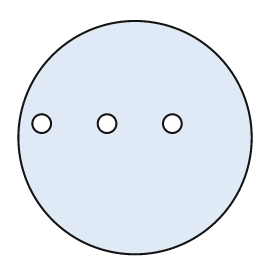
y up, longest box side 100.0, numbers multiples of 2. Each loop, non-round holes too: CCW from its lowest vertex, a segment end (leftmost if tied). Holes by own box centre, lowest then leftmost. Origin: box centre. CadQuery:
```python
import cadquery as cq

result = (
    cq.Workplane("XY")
    .moveTo(0.0, 0.0)
    .circle(50.0)
    .moveTo(-40.0, 6.0)
    .circle(4.0)
    .moveTo(-12.0, 6.0)
    .circle(4.0)
    .moveTo(16.0, 6.0)
    .circle(4.0)
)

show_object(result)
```